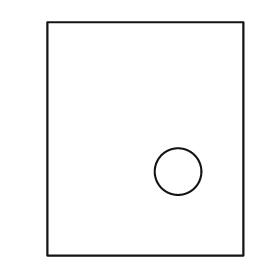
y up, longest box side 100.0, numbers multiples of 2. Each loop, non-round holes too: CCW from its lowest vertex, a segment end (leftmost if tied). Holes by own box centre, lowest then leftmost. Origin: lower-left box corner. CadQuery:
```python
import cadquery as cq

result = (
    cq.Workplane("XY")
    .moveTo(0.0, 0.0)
    .lineTo(84.0, 0.0)
    .lineTo(84.0, 100.0)
    .lineTo(0.0, 100.0)
    .close()
    .moveTo(56.0, 36.0)
    .circle(10.0)
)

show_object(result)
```